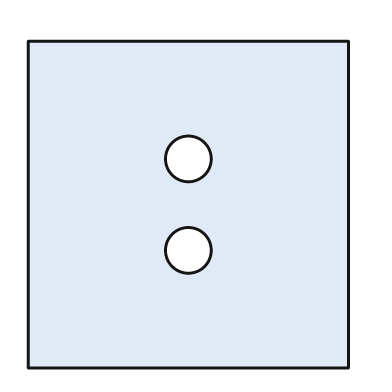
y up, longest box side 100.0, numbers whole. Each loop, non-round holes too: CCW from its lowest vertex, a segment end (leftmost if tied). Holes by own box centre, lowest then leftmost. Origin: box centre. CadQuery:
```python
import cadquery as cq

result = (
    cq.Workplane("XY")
    .moveTo(-49.0, -50.0)
    .lineTo(49.0, -50.0)
    .lineTo(49.0, 50.0)
    .lineTo(-49.0, 50.0)
    .close()
    .moveTo(0.0, -14.0)
    .circle(7.0)
    .moveTo(0.0, 14.0)
    .circle(7.0)
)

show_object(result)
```